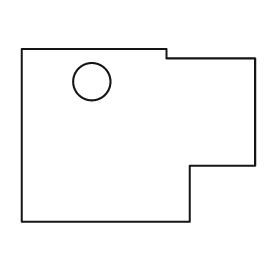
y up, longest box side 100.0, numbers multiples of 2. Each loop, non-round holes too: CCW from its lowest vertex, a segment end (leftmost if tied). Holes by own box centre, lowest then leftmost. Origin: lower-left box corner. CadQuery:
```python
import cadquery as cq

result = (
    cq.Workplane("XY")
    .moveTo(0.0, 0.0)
    .lineTo(72.0, 0.0)
    .lineTo(72.0, 24.0)
    .lineTo(100.0, 24.0)
    .lineTo(100.0, 70.0)
    .lineTo(62.0, 70.0)
    .lineTo(62.0, 74.0)
    .lineTo(0.0, 74.0)
    .close()
    .moveTo(30.0, 60.0)
    .circle(8.0)
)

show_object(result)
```